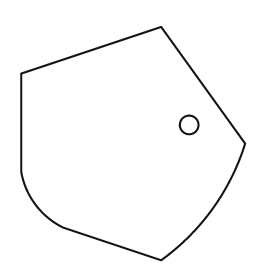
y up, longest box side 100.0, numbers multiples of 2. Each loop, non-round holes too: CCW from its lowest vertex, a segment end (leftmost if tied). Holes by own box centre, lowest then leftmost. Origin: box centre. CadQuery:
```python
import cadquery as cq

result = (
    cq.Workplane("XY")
    .moveTo(12.0, -50.0)
    .threePointArc((34.0, -28.0), (48.0, 0.0))
    .lineTo(12.0, 50.0)
    .lineTo(-48.0, 30.0)
    .lineTo(-48.0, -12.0)
    .threePointArc((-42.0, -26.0), (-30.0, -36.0))
    .close()
    .moveTo(24.0, 8.0)
    .circle(4.0)
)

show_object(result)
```